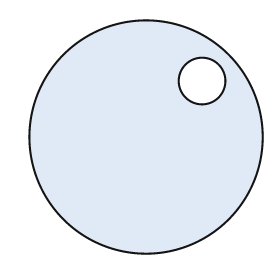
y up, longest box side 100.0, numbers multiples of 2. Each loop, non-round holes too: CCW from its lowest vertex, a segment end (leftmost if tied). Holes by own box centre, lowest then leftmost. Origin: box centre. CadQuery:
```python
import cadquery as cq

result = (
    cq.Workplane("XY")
    .moveTo(0.0, 0.0)
    .circle(50.0)
    .moveTo(24.0, 24.0)
    .circle(10.0)
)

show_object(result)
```